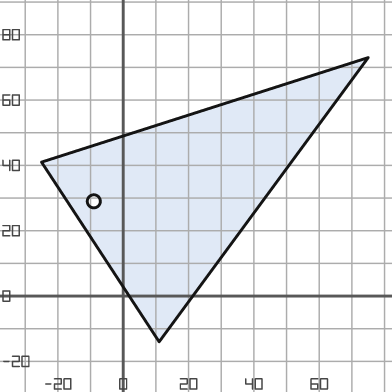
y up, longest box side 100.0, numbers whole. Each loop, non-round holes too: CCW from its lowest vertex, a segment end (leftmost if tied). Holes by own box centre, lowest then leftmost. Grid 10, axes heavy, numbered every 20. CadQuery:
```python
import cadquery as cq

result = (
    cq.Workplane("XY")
    .moveTo(11.0, -14.0)
    .lineTo(75.0, 73.0)
    .lineTo(-25.0, 41.0)
    .close()
    .moveTo(-9.0, 29.0)
    .circle(2.0)
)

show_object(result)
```